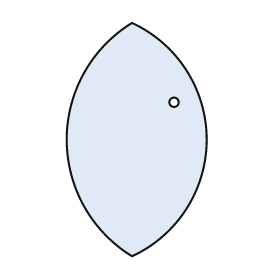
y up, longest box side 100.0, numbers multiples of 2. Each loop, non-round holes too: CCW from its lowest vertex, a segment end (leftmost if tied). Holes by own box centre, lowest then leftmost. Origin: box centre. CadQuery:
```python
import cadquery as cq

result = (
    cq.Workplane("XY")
    .moveTo(-2.0, -50.0)
    .threePointArc((30.0, 0.0), (-2.0, 50.0))
    .threePointArc((-30.0, 0.0), (-2.0, -50.0))
    .close()
    .moveTo(16.0, 16.0)
    .circle(2.0)
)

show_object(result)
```